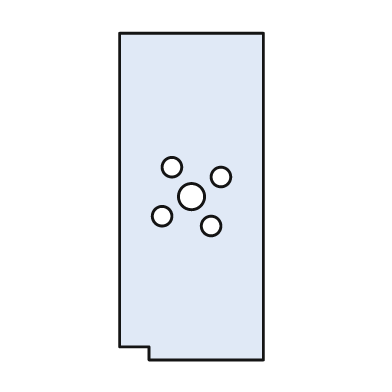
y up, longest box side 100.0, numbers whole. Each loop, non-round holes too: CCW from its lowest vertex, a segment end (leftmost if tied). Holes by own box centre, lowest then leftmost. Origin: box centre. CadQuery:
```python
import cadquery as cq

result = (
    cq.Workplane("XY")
    .moveTo(-13.0, -50.0)
    .lineTo(22.0, -50.0)
    .lineTo(22.0, 50.0)
    .lineTo(-22.0, 50.0)
    .lineTo(-22.0, -46.0)
    .lineTo(-13.0, -46.0)
    .close()
    .moveTo(6.0, -9.0)
    .circle(3.0)
    .moveTo(-9.0, -6.0)
    .circle(3.0)
    .moveTo(0.0, 0.0)
    .circle(4.0)
    .moveTo(9.0, 6.0)
    .circle(3.0)
    .moveTo(-6.0, 9.0)
    .circle(3.0)
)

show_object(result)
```